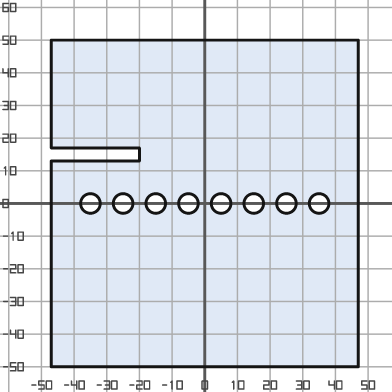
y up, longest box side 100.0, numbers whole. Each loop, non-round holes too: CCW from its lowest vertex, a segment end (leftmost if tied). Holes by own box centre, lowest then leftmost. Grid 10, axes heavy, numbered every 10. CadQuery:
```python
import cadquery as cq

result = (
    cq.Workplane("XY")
    .moveTo(-47.0, -50.0)
    .lineTo(47.0, -50.0)
    .lineTo(47.0, 50.0)
    .lineTo(-47.0, 50.0)
    .lineTo(-47.0, 17.0)
    .lineTo(-20.0, 17.0)
    .lineTo(-20.0, 13.0)
    .lineTo(-47.0, 13.0)
    .close()
    .moveTo(-35.0, 0.0)
    .circle(3.0)
    .moveTo(-25.0, 0.0)
    .circle(3.0)
    .moveTo(-15.0, 0.0)
    .circle(3.0)
    .moveTo(-5.0, 0.0)
    .circle(3.0)
    .moveTo(5.0, 0.0)
    .circle(3.0)
    .moveTo(15.0, 0.0)
    .circle(3.0)
    .moveTo(25.0, 0.0)
    .circle(3.0)
    .moveTo(35.0, 0.0)
    .circle(3.0)
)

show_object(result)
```